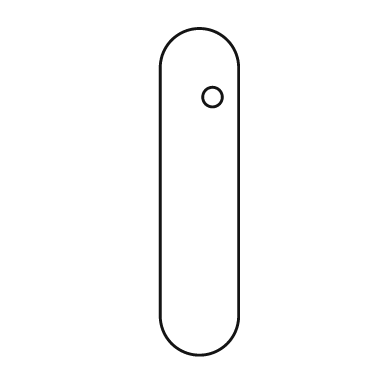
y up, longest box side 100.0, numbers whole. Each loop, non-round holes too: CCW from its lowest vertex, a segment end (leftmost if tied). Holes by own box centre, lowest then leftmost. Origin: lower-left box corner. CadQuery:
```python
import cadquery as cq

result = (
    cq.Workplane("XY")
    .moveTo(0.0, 12.0)
    .threePointArc((12.0, 0.0), (24.0, 12.0))
    .lineTo(24.0, 88.0)
    .threePointArc((12.0, 100.0), (0.0, 88.0))
    .close()
    .moveTo(16.0, 79.0)
    .circle(3.0)
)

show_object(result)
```